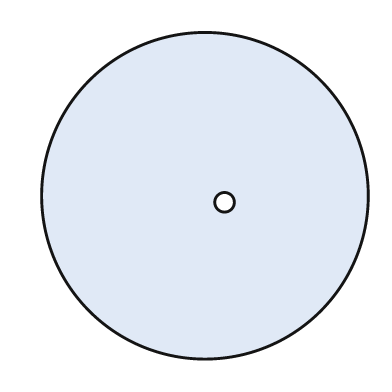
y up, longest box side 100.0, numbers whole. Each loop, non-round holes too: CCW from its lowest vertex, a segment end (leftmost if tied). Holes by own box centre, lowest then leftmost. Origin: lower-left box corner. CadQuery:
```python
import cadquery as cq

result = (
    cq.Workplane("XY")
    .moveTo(50.0, 50.0)
    .circle(50.0)
    .moveTo(56.0, 48.0)
    .circle(3.0)
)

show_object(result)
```